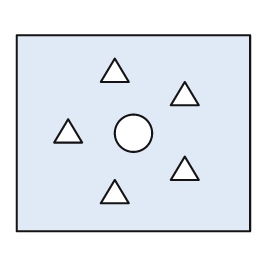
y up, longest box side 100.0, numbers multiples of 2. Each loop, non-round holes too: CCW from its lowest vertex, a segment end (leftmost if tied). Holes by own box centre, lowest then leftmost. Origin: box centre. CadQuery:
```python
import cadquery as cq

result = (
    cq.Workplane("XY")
    .moveTo(-50.0, -42.0)
    .lineTo(50.0, -42.0)
    .lineTo(50.0, 42.0)
    .lineTo(-50.0, 42.0)
    .close()
    .moveTo(-14.0, -30.0)
    .lineTo(-2.0, -30.0)
    .lineTo(-8.0, -20.0)
    .close()
    .moveTo(16.0, -20.0)
    .lineTo(28.0, -20.0)
    .lineTo(22.0, -10.0)
    .close()
    .moveTo(0.0, 0.0)
    .circle(8.0)
    .moveTo(-34.0, -4.0)
    .lineTo(-22.0, -4.0)
    .lineTo(-28.0, 6.0)
    .close()
    .moveTo(16.0, 12.0)
    .lineTo(28.0, 12.0)
    .lineTo(22.0, 22.0)
    .close()
    .moveTo(-14.0, 22.0)
    .lineTo(-2.0, 22.0)
    .lineTo(-8.0, 32.0)
    .close()
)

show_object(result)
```